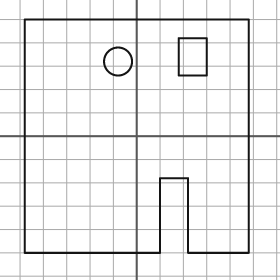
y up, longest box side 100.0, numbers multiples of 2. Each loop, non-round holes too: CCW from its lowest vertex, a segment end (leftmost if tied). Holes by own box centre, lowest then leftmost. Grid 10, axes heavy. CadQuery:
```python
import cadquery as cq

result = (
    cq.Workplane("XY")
    .moveTo(-48.0, -50.0)
    .lineTo(10.0, -50.0)
    .lineTo(10.0, -18.0)
    .lineTo(22.0, -18.0)
    .lineTo(22.0, -50.0)
    .lineTo(48.0, -50.0)
    .lineTo(48.0, 50.0)
    .lineTo(-48.0, 50.0)
    .close()
    .moveTo(-8.0, 32.0)
    .circle(6.0)
    .moveTo(18.0, 26.0)
    .lineTo(30.0, 26.0)
    .lineTo(30.0, 42.0)
    .lineTo(18.0, 42.0)
    .close()
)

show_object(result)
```